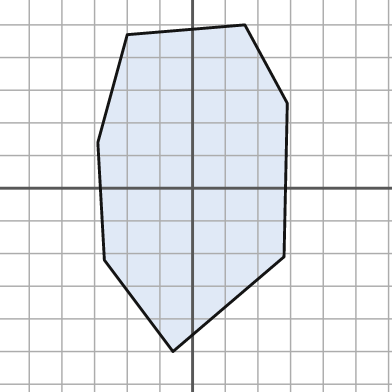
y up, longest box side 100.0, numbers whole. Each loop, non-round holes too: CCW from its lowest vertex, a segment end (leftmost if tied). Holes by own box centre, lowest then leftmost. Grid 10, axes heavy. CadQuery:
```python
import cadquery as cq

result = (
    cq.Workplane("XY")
    .moveTo(-6.0, -50.0)
    .lineTo(28.0, -21.0)
    .lineTo(29.0, 26.0)
    .lineTo(16.0, 50.0)
    .lineTo(-20.0, 47.0)
    .lineTo(-29.0, 14.0)
    .lineTo(-27.0, -22.0)
    .close()
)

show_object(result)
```